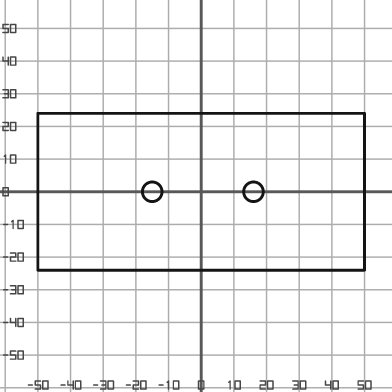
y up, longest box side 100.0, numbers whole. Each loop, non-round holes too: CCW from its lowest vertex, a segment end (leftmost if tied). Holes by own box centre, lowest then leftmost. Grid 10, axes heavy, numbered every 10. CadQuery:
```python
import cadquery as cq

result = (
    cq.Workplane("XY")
    .moveTo(-50.0, -24.0)
    .lineTo(50.0, -24.0)
    .lineTo(50.0, 24.0)
    .lineTo(-50.0, 24.0)
    .close()
    .moveTo(-15.0, 0.0)
    .circle(3.0)
    .moveTo(16.0, 0.0)
    .circle(3.0)
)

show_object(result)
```